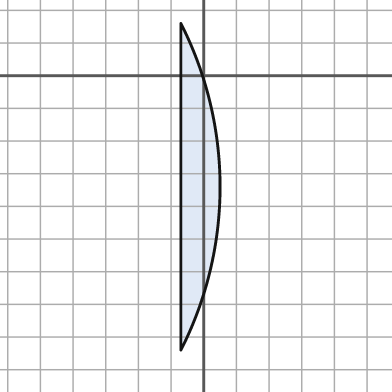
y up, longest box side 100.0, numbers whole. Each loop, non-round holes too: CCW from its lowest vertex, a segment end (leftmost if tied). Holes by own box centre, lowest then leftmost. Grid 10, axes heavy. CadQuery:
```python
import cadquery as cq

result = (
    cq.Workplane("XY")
    .moveTo(-7.0, -84.0)
    .threePointArc((5.0, -34.0), (-7.0, 16.0))
    .close()
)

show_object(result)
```